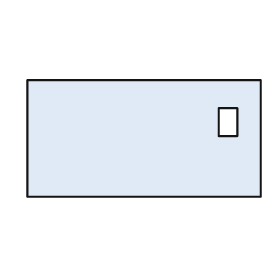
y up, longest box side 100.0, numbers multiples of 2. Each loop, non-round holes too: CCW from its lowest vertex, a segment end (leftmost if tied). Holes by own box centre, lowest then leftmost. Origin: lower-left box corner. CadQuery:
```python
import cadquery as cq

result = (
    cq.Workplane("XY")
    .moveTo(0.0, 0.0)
    .lineTo(100.0, 0.0)
    .lineTo(100.0, 50.0)
    .lineTo(0.0, 50.0)
    .close()
    .moveTo(82.0, 26.0)
    .lineTo(90.0, 26.0)
    .lineTo(90.0, 38.0)
    .lineTo(82.0, 38.0)
    .close()
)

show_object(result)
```